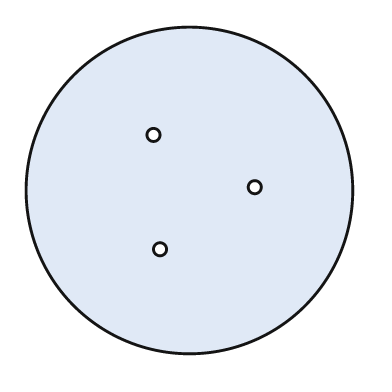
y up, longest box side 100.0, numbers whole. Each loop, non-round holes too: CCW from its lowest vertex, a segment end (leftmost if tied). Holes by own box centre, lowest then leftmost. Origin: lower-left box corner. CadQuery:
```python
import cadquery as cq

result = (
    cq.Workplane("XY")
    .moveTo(50.0, 50.0)
    .circle(50.0)
    .moveTo(41.0, 32.0)
    .circle(2.0)
    .moveTo(70.0, 51.0)
    .circle(2.0)
    .moveTo(39.0, 67.0)
    .circle(2.0)
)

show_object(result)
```